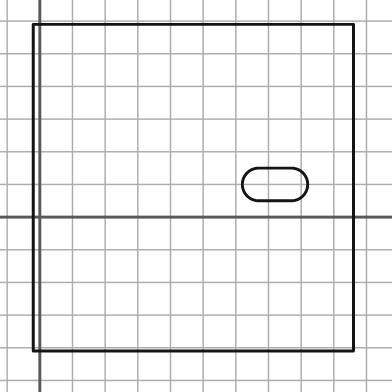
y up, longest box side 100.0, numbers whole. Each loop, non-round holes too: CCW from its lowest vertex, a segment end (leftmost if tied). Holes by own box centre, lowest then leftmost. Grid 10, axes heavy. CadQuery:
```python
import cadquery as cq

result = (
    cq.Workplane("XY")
    .moveTo(-2.0, -41.0)
    .lineTo(96.0, -41.0)
    .lineTo(96.0, 59.0)
    .lineTo(-2.0, 59.0)
    .close()
    .moveTo(67.0, 5.0)
    .lineTo(77.0, 5.0)
    .threePointArc((82.0, 10.0), (77.0, 15.0))
    .lineTo(67.0, 15.0)
    .threePointArc((62.0, 10.0), (67.0, 5.0))
    .close()
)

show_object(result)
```